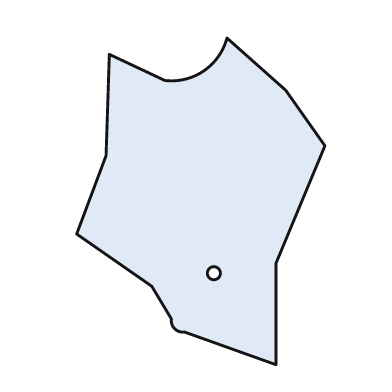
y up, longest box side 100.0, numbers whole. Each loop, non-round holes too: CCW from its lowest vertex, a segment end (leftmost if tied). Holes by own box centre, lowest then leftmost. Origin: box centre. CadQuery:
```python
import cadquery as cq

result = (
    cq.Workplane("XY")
    .moveTo(23.0, -50.0)
    .lineTo(23.0, -19.0)
    .lineTo(38.0, 17.0)
    .lineTo(26.0, 34.0)
    .lineTo(8.0, 50.0)
    .threePointArc((1.0, 40.0), (-11.0, 37.0))
    .lineTo(-28.0, 45.0)
    .lineTo(-29.0, 14.0)
    .lineTo(-38.0, -10.0)
    .lineTo(-15.0, -26.0)
    .lineTo(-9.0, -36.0)
    .threePointArc((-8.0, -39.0), (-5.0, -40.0))
    .close()
    .moveTo(4.0, -22.0)
    .circle(2.0)
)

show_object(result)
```